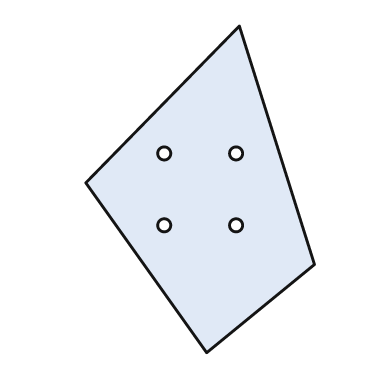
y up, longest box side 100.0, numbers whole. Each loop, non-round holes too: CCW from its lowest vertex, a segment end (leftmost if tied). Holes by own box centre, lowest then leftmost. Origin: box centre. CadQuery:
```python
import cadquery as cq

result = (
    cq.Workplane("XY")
    .moveTo(2.0, -50.0)
    .lineTo(35.0, -23.0)
    .lineTo(12.0, 50.0)
    .lineTo(-35.0, 2.0)
    .close()
    .moveTo(-11.0, -11.0)
    .circle(2.0)
    .moveTo(11.0, -11.0)
    .circle(2.0)
    .moveTo(-11.0, 11.0)
    .circle(2.0)
    .moveTo(11.0, 11.0)
    .circle(2.0)
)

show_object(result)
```